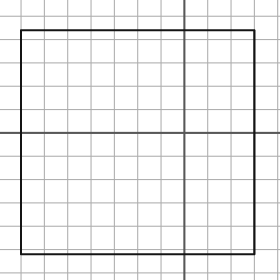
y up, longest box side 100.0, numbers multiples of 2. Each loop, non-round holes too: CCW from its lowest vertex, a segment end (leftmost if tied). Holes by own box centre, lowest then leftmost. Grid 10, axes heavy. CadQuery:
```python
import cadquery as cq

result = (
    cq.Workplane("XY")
    .moveTo(-70.0, -52.0)
    .lineTo(30.0, -52.0)
    .lineTo(30.0, 44.0)
    .lineTo(-70.0, 44.0)
    .close()
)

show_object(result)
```